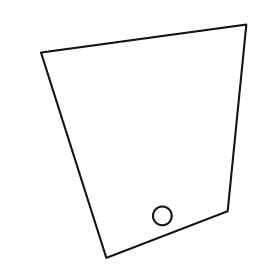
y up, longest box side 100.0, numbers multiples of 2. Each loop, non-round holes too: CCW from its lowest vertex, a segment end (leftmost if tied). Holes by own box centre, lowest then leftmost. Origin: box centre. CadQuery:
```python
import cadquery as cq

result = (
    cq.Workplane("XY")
    .moveTo(-16.0, -50.0)
    .lineTo(36.0, -30.0)
    .lineTo(44.0, 50.0)
    .lineTo(-44.0, 38.0)
    .close()
    .moveTo(8.0, -32.0)
    .circle(4.0)
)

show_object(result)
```